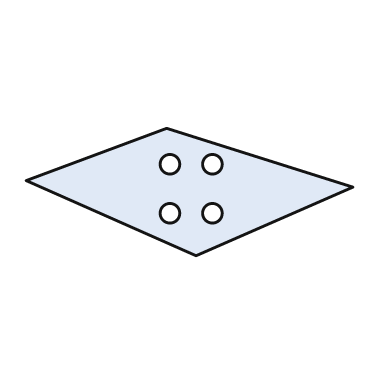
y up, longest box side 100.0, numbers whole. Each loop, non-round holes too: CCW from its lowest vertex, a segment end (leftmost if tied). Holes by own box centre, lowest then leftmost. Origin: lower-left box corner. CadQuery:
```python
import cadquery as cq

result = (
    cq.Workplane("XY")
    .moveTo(52.0, 0.0)
    .lineTo(100.0, 21.0)
    .lineTo(43.0, 39.0)
    .lineTo(0.0, 23.0)
    .close()
    .moveTo(44.0, 13.0)
    .circle(3.0)
    .moveTo(57.0, 13.0)
    .circle(3.0)
    .moveTo(44.0, 28.0)
    .circle(3.0)
    .moveTo(57.0, 28.0)
    .circle(3.0)
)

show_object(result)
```